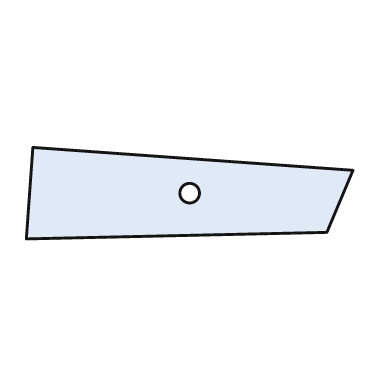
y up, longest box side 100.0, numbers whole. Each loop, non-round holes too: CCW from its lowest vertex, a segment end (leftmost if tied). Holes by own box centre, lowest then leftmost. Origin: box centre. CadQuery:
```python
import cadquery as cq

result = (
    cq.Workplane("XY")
    .moveTo(-50.0, -14.0)
    .lineTo(42.0, -12.0)
    .lineTo(50.0, 7.0)
    .lineTo(-48.0, 14.0)
    .close()
    .moveTo(0.0, 0.0)
    .circle(3.0)
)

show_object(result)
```